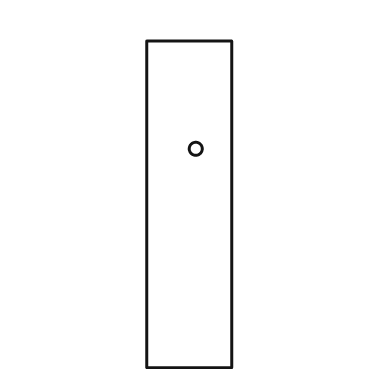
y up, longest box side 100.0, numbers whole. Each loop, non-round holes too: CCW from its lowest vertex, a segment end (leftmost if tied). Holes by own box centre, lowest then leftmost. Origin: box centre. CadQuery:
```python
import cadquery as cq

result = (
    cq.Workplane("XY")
    .moveTo(-13.0, -50.0)
    .lineTo(13.0, -50.0)
    .lineTo(13.0, 50.0)
    .lineTo(-13.0, 50.0)
    .close()
    .moveTo(2.0, 17.0)
    .circle(2.0)
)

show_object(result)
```